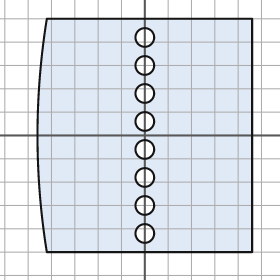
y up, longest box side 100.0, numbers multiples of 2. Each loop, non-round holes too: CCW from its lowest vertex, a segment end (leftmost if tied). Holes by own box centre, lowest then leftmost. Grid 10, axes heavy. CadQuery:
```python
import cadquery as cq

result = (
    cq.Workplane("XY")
    .moveTo(-42.0, -50.0)
    .lineTo(46.0, -50.0)
    .lineTo(46.0, 50.0)
    .lineTo(-42.0, 50.0)
    .threePointArc((-46.0, 0.0), (-42.0, -50.0))
    .close()
    .moveTo(0.0, -42.0)
    .circle(4.0)
    .moveTo(0.0, -30.0)
    .circle(4.0)
    .moveTo(0.0, -18.0)
    .circle(4.0)
    .moveTo(0.0, -6.0)
    .circle(4.0)
    .moveTo(0.0, 6.0)
    .circle(4.0)
    .moveTo(0.0, 18.0)
    .circle(4.0)
    .moveTo(0.0, 30.0)
    .circle(4.0)
    .moveTo(0.0, 42.0)
    .circle(4.0)
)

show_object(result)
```